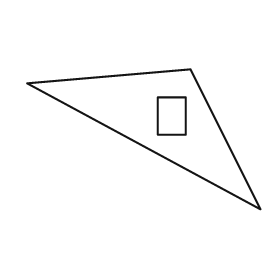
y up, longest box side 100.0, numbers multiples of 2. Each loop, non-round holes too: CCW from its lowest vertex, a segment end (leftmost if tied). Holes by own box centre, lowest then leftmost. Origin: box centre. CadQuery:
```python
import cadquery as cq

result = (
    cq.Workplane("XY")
    .moveTo(50.0, -30.0)
    .lineTo(20.0, 30.0)
    .lineTo(-50.0, 24.0)
    .close()
    .moveTo(6.0, 2.0)
    .lineTo(18.0, 2.0)
    .lineTo(18.0, 18.0)
    .lineTo(6.0, 18.0)
    .close()
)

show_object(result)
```